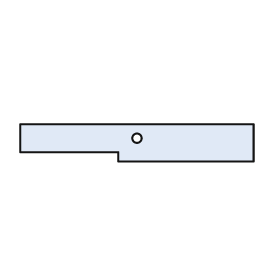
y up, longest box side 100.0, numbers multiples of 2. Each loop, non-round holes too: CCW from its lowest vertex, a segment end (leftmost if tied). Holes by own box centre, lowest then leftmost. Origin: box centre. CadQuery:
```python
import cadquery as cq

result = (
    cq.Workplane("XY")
    .moveTo(-8.0, -8.0)
    .lineTo(50.0, -8.0)
    .lineTo(50.0, 8.0)
    .lineTo(-50.0, 8.0)
    .lineTo(-50.0, -4.0)
    .lineTo(-8.0, -4.0)
    .close()
    .moveTo(0.0, 2.0)
    .circle(2.0)
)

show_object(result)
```